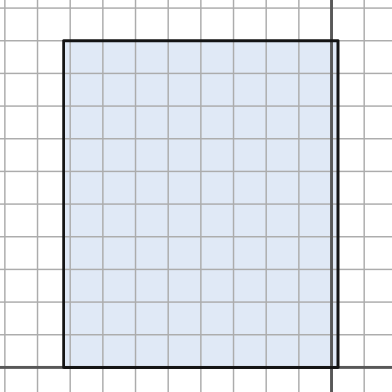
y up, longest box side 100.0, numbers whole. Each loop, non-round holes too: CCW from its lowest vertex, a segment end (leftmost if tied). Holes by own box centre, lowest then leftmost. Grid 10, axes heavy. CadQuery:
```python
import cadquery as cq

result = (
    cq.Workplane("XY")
    .moveTo(-82.0, 0.0)
    .lineTo(2.0, 0.0)
    .lineTo(2.0, 100.0)
    .lineTo(-82.0, 100.0)
    .close()
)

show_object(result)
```